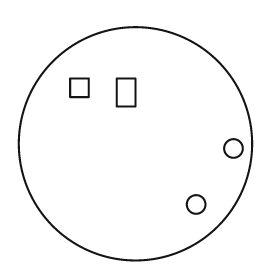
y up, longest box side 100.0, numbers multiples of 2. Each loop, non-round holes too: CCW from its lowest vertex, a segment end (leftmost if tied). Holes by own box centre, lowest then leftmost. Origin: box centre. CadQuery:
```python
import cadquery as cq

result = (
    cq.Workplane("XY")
    .moveTo(0.0, 0.0)
    .circle(50.0)
    .moveTo(26.0, -26.0)
    .circle(4.0)
    .moveTo(42.0, -2.0)
    .circle(4.0)
    .moveTo(-8.0, 16.0)
    .lineTo(0.0, 16.0)
    .lineTo(0.0, 28.0)
    .lineTo(-8.0, 28.0)
    .close()
    .moveTo(-28.0, 20.0)
    .lineTo(-20.0, 20.0)
    .lineTo(-20.0, 28.0)
    .lineTo(-28.0, 28.0)
    .close()
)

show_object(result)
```